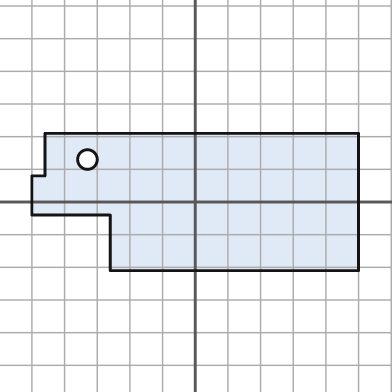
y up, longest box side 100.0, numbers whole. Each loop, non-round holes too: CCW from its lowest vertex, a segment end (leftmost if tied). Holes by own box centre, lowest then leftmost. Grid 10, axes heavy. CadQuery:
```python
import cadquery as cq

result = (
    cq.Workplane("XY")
    .moveTo(-26.0, -21.0)
    .lineTo(50.0, -21.0)
    .lineTo(50.0, 21.0)
    .lineTo(-46.0, 21.0)
    .lineTo(-46.0, 8.0)
    .lineTo(-50.0, 8.0)
    .lineTo(-50.0, -4.0)
    .lineTo(-26.0, -4.0)
    .close()
    .moveTo(-33.0, 13.0)
    .circle(3.0)
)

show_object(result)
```